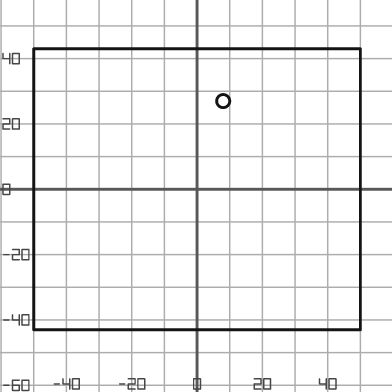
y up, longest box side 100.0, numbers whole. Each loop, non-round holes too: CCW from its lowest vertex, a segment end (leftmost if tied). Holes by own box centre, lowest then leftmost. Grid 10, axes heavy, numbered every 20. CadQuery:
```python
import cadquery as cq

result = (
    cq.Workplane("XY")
    .moveTo(-50.0, -43.0)
    .lineTo(50.0, -43.0)
    .lineTo(50.0, 43.0)
    .lineTo(-50.0, 43.0)
    .close()
    .moveTo(8.0, 27.0)
    .circle(2.0)
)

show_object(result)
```